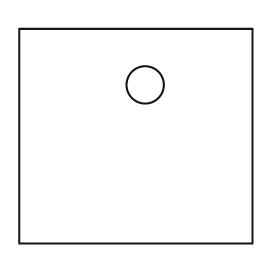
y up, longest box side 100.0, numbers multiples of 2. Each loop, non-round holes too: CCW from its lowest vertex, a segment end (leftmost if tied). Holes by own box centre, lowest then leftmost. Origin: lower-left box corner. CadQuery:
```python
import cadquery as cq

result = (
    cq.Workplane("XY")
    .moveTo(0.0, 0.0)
    .lineTo(100.0, 0.0)
    .lineTo(100.0, 92.0)
    .lineTo(0.0, 92.0)
    .close()
    .moveTo(54.0, 68.0)
    .circle(8.0)
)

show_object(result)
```